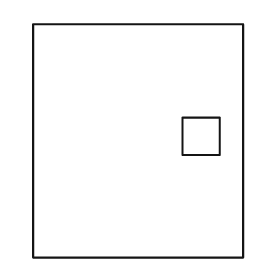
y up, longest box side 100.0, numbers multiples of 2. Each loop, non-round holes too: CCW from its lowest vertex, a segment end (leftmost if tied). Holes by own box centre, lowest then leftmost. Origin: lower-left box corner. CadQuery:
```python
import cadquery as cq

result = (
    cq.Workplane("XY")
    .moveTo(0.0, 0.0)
    .lineTo(90.0, 0.0)
    .lineTo(90.0, 100.0)
    .lineTo(0.0, 100.0)
    .close()
    .moveTo(64.0, 44.0)
    .lineTo(80.0, 44.0)
    .lineTo(80.0, 60.0)
    .lineTo(64.0, 60.0)
    .close()
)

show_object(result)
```